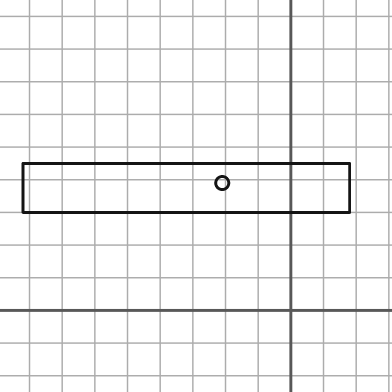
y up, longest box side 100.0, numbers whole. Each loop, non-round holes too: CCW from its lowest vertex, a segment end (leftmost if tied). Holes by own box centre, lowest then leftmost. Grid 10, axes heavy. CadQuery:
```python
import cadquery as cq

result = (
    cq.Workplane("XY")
    .moveTo(-82.0, 30.0)
    .lineTo(18.0, 30.0)
    .lineTo(18.0, 45.0)
    .lineTo(-82.0, 45.0)
    .close()
    .moveTo(-21.0, 39.0)
    .circle(2.0)
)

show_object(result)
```